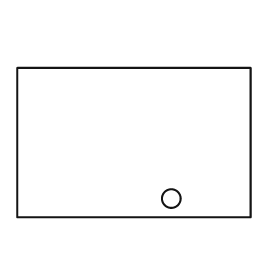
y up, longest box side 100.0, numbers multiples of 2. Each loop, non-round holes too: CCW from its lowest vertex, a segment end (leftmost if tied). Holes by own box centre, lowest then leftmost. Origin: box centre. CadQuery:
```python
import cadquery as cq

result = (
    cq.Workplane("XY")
    .moveTo(-50.0, -32.0)
    .lineTo(50.0, -32.0)
    .lineTo(50.0, 32.0)
    .lineTo(-50.0, 32.0)
    .close()
    .moveTo(16.0, -24.0)
    .circle(4.0)
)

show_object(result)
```